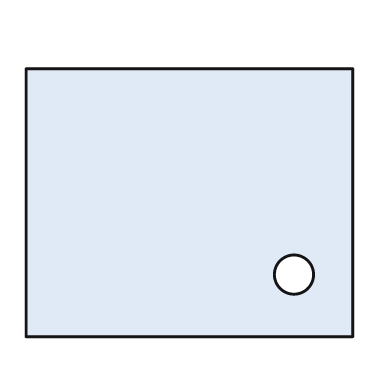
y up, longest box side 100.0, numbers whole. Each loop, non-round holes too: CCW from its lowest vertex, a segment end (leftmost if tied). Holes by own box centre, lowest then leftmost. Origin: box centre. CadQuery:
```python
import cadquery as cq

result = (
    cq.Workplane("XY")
    .moveTo(-50.0, -41.0)
    .lineTo(50.0, -41.0)
    .lineTo(50.0, 41.0)
    .lineTo(-50.0, 41.0)
    .close()
    .moveTo(32.0, -22.0)
    .circle(6.0)
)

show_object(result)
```